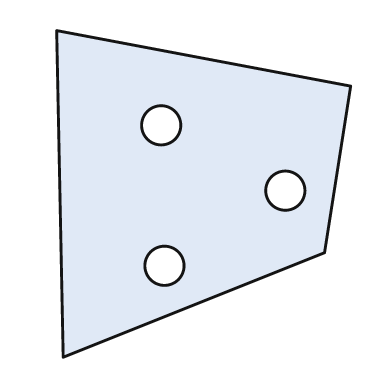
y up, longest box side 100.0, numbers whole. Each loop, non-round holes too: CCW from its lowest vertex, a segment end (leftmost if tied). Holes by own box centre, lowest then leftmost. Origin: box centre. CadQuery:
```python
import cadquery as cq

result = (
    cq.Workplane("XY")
    .moveTo(-43.0, -50.0)
    .lineTo(37.0, -18.0)
    .lineTo(45.0, 33.0)
    .lineTo(-45.0, 50.0)
    .close()
    .moveTo(-12.0, -22.0)
    .circle(6.0)
    .moveTo(25.0, 1.0)
    .circle(6.0)
    .moveTo(-13.0, 21.0)
    .circle(6.0)
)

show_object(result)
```